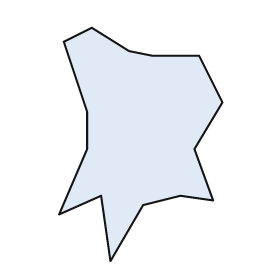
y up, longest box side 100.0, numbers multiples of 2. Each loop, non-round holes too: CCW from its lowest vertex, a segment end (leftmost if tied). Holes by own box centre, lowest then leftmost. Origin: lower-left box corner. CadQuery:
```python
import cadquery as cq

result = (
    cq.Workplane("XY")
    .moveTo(22.0, 0.0)
    .lineTo(36.0, 24.0)
    .lineTo(52.0, 28.0)
    .lineTo(66.0, 26.0)
    .lineTo(58.0, 48.0)
    .lineTo(70.0, 68.0)
    .lineTo(60.0, 88.0)
    .lineTo(40.0, 88.0)
    .lineTo(30.0, 90.0)
    .lineTo(14.0, 100.0)
    .lineTo(2.0, 94.0)
    .lineTo(12.0, 64.0)
    .lineTo(12.0, 48.0)
    .lineTo(0.0, 20.0)
    .lineTo(18.0, 28.0)
    .close()
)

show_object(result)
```